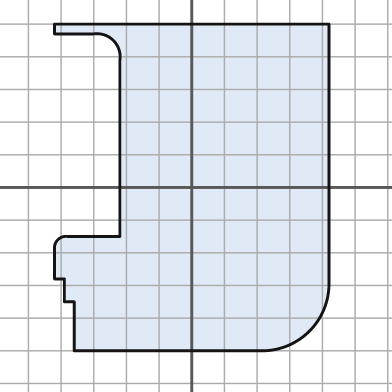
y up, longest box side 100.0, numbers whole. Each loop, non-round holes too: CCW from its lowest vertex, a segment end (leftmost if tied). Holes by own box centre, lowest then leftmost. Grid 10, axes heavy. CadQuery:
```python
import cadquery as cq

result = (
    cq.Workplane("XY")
    .moveTo(-36.0, -50.0)
    .lineTo(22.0, -50.0)
    .threePointArc((36.0, -44.0), (42.0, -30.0))
    .lineTo(42.0, 50.0)
    .lineTo(-42.0, 50.0)
    .lineTo(-42.0, 47.0)
    .lineTo(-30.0, 47.0)
    .threePointArc((-24.0, 45.0), (-22.0, 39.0))
    .lineTo(-22.0, -15.0)
    .lineTo(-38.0, -15.0)
    .threePointArc((-41.0, -16.0), (-42.0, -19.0))
    .lineTo(-42.0, -28.0)
    .lineTo(-39.0, -28.0)
    .lineTo(-39.0, -35.0)
    .lineTo(-36.0, -35.0)
    .close()
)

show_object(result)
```